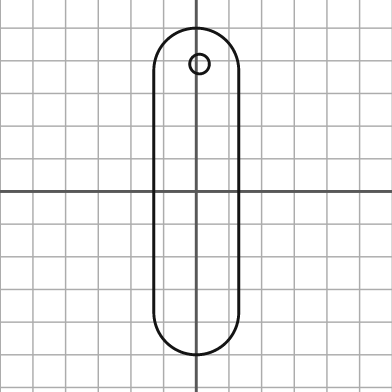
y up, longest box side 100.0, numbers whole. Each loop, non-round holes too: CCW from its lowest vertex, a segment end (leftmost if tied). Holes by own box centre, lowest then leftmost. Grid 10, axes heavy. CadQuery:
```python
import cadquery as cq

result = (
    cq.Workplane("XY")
    .moveTo(-13.0, -37.0)
    .threePointArc((0.0, -50.0), (13.0, -37.0))
    .lineTo(13.0, 37.0)
    .threePointArc((0.0, 50.0), (-13.0, 37.0))
    .close()
    .moveTo(1.0, 39.0)
    .circle(3.0)
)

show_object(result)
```